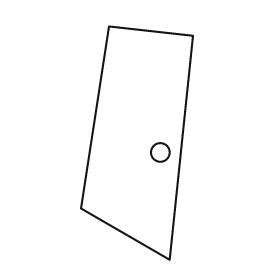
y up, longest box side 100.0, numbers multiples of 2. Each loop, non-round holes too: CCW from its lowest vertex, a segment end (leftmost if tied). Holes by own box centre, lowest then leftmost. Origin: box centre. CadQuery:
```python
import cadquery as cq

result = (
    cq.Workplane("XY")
    .moveTo(14.0, -50.0)
    .lineTo(24.0, 46.0)
    .lineTo(-12.0, 50.0)
    .lineTo(-24.0, -28.0)
    .close()
    .moveTo(10.0, -4.0)
    .circle(4.0)
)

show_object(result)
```